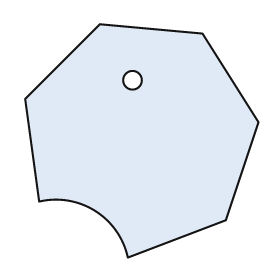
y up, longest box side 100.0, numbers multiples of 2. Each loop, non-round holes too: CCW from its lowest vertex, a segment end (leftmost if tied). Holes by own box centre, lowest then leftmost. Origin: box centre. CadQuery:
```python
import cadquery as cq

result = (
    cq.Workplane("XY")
    .moveTo(-6.0, -50.0)
    .lineTo(36.0, -34.0)
    .lineTo(50.0, 8.0)
    .lineTo(26.0, 46.0)
    .lineTo(-18.0, 50.0)
    .lineTo(-50.0, 18.0)
    .lineTo(-44.0, -26.0)
    .threePointArc((-20.0, -30.0), (-6.0, -50.0))
    .close()
    .moveTo(-4.0, 26.0)
    .circle(4.0)
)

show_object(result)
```